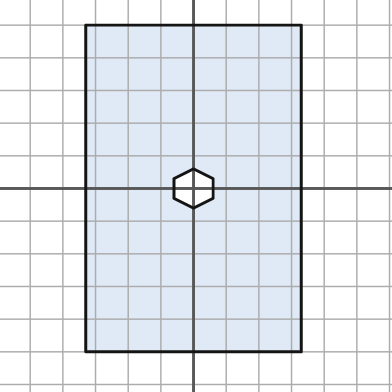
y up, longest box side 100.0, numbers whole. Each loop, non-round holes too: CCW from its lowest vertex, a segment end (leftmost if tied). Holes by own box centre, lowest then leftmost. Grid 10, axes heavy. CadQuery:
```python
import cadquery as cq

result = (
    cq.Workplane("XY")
    .moveTo(-33.0, -50.0)
    .lineTo(33.0, -50.0)
    .lineTo(33.0, 50.0)
    .lineTo(-33.0, 50.0)
    .close()
    .moveTo(0.0, -6.0)
    .lineTo(6.0, -3.0)
    .lineTo(6.0, 3.0)
    .lineTo(0.0, 6.0)
    .lineTo(-6.0, 3.0)
    .lineTo(-6.0, -3.0)
    .close()
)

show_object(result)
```